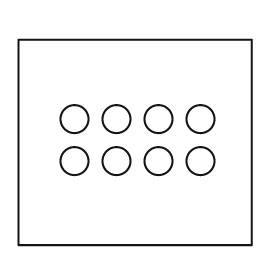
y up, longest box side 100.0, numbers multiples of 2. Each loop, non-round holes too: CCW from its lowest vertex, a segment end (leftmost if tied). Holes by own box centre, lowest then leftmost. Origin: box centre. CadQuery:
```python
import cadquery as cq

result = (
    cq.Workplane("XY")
    .moveTo(-50.0, -44.0)
    .lineTo(50.0, -44.0)
    .lineTo(50.0, 44.0)
    .lineTo(-50.0, 44.0)
    .close()
    .moveTo(-26.0, -8.0)
    .circle(6.0)
    .moveTo(-8.0, -8.0)
    .circle(6.0)
    .moveTo(10.0, -8.0)
    .circle(6.0)
    .moveTo(28.0, -8.0)
    .circle(6.0)
    .moveTo(-26.0, 10.0)
    .circle(6.0)
    .moveTo(-8.0, 10.0)
    .circle(6.0)
    .moveTo(10.0, 10.0)
    .circle(6.0)
    .moveTo(28.0, 10.0)
    .circle(6.0)
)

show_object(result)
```